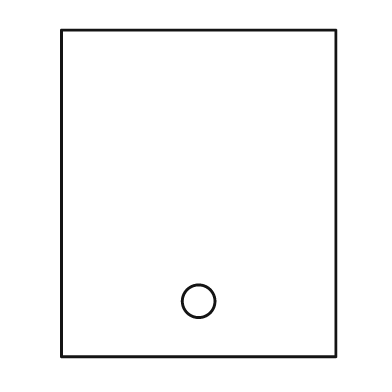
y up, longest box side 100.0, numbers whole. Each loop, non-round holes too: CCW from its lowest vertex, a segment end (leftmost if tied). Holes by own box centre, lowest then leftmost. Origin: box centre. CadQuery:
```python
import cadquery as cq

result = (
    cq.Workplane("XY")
    .moveTo(-42.0, -50.0)
    .lineTo(42.0, -50.0)
    .lineTo(42.0, 50.0)
    .lineTo(-42.0, 50.0)
    .close()
    .moveTo(0.0, -33.0)
    .circle(5.0)
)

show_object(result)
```